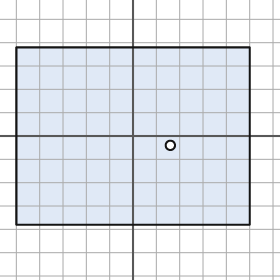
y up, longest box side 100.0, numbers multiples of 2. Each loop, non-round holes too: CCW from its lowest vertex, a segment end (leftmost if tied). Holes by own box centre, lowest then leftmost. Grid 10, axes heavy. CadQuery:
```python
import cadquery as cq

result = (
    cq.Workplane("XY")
    .moveTo(-50.0, -38.0)
    .lineTo(50.0, -38.0)
    .lineTo(50.0, 38.0)
    .lineTo(-50.0, 38.0)
    .close()
    .moveTo(16.0, -4.0)
    .circle(2.0)
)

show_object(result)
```